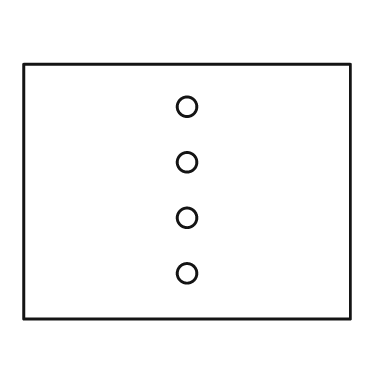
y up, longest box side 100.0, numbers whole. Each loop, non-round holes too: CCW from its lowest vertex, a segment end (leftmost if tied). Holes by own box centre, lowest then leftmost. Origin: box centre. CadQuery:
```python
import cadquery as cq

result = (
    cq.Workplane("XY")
    .moveTo(-50.0, -39.0)
    .lineTo(50.0, -39.0)
    .lineTo(50.0, 39.0)
    .lineTo(-50.0, 39.0)
    .close()
    .moveTo(0.0, -25.0)
    .circle(3.0)
    .moveTo(0.0, -8.0)
    .circle(3.0)
    .moveTo(0.0, 9.0)
    .circle(3.0)
    .moveTo(0.0, 26.0)
    .circle(3.0)
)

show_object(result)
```